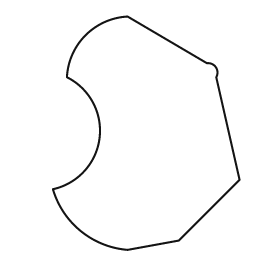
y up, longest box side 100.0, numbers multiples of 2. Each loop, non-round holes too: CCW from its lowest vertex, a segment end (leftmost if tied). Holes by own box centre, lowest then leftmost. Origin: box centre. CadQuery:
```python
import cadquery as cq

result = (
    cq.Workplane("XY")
    .moveTo(-8.0, -50.0)
    .lineTo(14.0, -46.0)
    .lineTo(40.0, -20.0)
    .lineTo(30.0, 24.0)
    .threePointArc((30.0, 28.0), (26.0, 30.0))
    .lineTo(-8.0, 50.0)
    .threePointArc((-26.0, 42.0), (-34.0, 24.0))
    .threePointArc((-20.0, -2.0), (-40.0, -24.0))
    .threePointArc((-28.0, -42.0), (-8.0, -50.0))
    .close()
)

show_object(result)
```